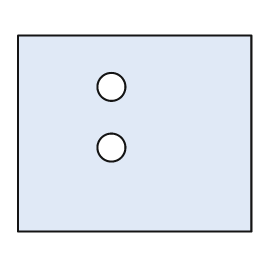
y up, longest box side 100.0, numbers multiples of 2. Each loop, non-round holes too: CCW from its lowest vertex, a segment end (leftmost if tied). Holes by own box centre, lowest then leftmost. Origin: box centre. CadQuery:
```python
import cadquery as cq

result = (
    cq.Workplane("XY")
    .moveTo(-50.0, -42.0)
    .lineTo(50.0, -42.0)
    .lineTo(50.0, 42.0)
    .lineTo(-50.0, 42.0)
    .close()
    .moveTo(-10.0, -6.0)
    .circle(6.0)
    .moveTo(-10.0, 20.0)
    .circle(6.0)
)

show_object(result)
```